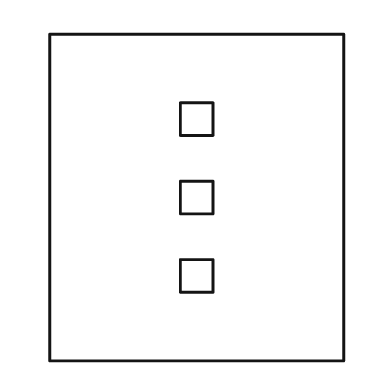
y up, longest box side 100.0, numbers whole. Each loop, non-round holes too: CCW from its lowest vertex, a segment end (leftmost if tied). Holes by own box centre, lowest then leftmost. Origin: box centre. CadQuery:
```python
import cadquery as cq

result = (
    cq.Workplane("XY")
    .moveTo(-45.0, -50.0)
    .lineTo(45.0, -50.0)
    .lineTo(45.0, 50.0)
    .lineTo(-45.0, 50.0)
    .close()
    .moveTo(-5.0, -29.0)
    .lineTo(5.0, -29.0)
    .lineTo(5.0, -19.0)
    .lineTo(-5.0, -19.0)
    .close()
    .moveTo(-5.0, -5.0)
    .lineTo(5.0, -5.0)
    .lineTo(5.0, 5.0)
    .lineTo(-5.0, 5.0)
    .close()
    .moveTo(-5.0, 19.0)
    .lineTo(5.0, 19.0)
    .lineTo(5.0, 29.0)
    .lineTo(-5.0, 29.0)
    .close()
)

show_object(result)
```